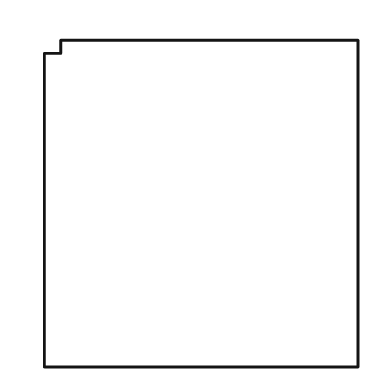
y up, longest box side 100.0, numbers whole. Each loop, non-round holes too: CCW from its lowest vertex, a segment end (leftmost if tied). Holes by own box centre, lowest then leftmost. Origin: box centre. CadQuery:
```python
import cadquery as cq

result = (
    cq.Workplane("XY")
    .moveTo(-48.0, -50.0)
    .lineTo(48.0, -50.0)
    .lineTo(48.0, 50.0)
    .lineTo(-43.0, 50.0)
    .lineTo(-43.0, 46.0)
    .lineTo(-48.0, 46.0)
    .close()
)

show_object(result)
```